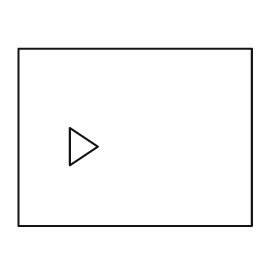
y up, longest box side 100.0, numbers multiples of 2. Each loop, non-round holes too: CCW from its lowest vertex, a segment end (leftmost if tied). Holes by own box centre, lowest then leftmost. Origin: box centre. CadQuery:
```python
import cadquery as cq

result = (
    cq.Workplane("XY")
    .moveTo(-50.0, -38.0)
    .lineTo(50.0, -38.0)
    .lineTo(50.0, 38.0)
    .lineTo(-50.0, 38.0)
    .close()
    .moveTo(-28.0, -12.0)
    .lineTo(-16.0, -4.0)
    .lineTo(-28.0, 4.0)
    .close()
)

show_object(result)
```